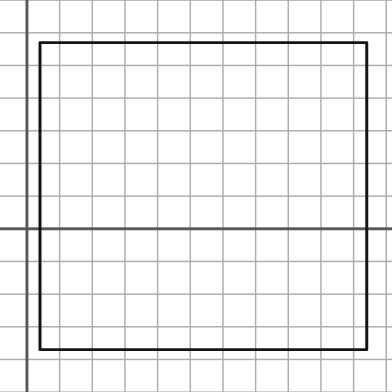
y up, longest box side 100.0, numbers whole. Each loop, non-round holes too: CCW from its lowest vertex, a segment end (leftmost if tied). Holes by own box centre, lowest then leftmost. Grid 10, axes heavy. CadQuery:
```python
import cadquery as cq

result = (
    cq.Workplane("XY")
    .moveTo(4.0, -37.0)
    .lineTo(104.0, -37.0)
    .lineTo(104.0, 57.0)
    .lineTo(4.0, 57.0)
    .close()
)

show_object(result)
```